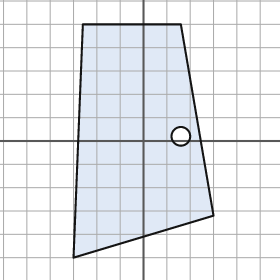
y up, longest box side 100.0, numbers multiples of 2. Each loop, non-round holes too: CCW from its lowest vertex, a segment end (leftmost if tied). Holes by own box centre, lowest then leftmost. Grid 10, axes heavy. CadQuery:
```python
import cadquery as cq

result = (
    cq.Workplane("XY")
    .moveTo(-30.0, -50.0)
    .lineTo(30.0, -32.0)
    .lineTo(16.0, 50.0)
    .lineTo(-26.0, 50.0)
    .close()
    .moveTo(16.0, 2.0)
    .circle(4.0)
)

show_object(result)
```